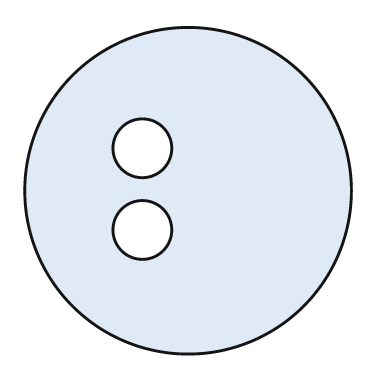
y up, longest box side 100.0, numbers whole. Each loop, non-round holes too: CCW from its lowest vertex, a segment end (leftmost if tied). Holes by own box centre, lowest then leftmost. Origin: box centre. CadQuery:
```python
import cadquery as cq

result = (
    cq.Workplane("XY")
    .moveTo(0.0, 0.0)
    .circle(50.0)
    .moveTo(-14.0, -12.0)
    .circle(9.0)
    .moveTo(-14.0, 13.0)
    .circle(9.0)
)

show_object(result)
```